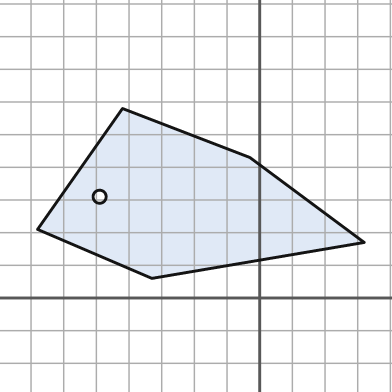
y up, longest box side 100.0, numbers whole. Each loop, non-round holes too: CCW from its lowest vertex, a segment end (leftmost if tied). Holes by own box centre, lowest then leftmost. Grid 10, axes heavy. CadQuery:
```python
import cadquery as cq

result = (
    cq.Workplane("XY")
    .moveTo(-33.0, 6.0)
    .lineTo(32.0, 17.0)
    .lineTo(-3.0, 43.0)
    .lineTo(-42.0, 58.0)
    .lineTo(-68.0, 21.0)
    .close()
    .moveTo(-49.0, 31.0)
    .circle(2.0)
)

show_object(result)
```